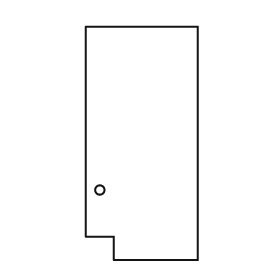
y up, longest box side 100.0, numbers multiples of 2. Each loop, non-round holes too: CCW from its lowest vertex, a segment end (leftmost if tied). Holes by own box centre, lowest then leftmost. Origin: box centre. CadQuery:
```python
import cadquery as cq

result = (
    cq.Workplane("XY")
    .moveTo(-12.0, -50.0)
    .lineTo(24.0, -50.0)
    .lineTo(24.0, 50.0)
    .lineTo(-24.0, 50.0)
    .lineTo(-24.0, -40.0)
    .lineTo(-12.0, -40.0)
    .close()
    .moveTo(-18.0, -20.0)
    .circle(2.0)
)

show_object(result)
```